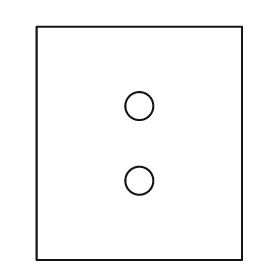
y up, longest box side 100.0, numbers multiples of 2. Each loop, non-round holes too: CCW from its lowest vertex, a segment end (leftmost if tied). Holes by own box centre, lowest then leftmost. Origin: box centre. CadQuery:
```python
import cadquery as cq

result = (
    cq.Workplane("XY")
    .moveTo(-44.0, -50.0)
    .lineTo(44.0, -50.0)
    .lineTo(44.0, 50.0)
    .lineTo(-44.0, 50.0)
    .close()
    .moveTo(0.0, -16.0)
    .circle(6.0)
    .moveTo(0.0, 16.0)
    .circle(6.0)
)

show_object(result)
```